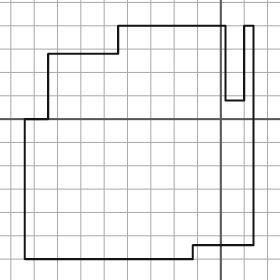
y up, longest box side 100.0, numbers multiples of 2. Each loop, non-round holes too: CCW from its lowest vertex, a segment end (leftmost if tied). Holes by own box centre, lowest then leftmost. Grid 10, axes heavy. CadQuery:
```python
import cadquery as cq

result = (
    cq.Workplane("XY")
    .moveTo(-84.0, -60.0)
    .lineTo(-12.0, -60.0)
    .lineTo(-12.0, -54.0)
    .lineTo(14.0, -54.0)
    .lineTo(14.0, 40.0)
    .lineTo(10.0, 40.0)
    .lineTo(10.0, 8.0)
    .lineTo(2.0, 8.0)
    .lineTo(2.0, 40.0)
    .lineTo(-44.0, 40.0)
    .lineTo(-44.0, 28.0)
    .lineTo(-74.0, 28.0)
    .lineTo(-74.0, 0.0)
    .lineTo(-84.0, 0.0)
    .close()
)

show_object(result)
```